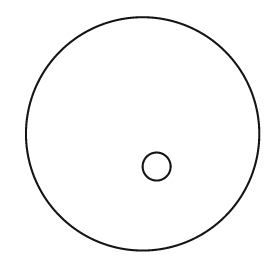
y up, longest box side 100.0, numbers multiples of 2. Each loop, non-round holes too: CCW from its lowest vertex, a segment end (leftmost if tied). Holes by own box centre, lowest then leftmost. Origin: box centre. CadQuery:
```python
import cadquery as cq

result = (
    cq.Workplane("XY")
    .moveTo(0.0, 0.0)
    .circle(50.0)
    .moveTo(6.0, -14.0)
    .circle(6.0)
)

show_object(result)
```